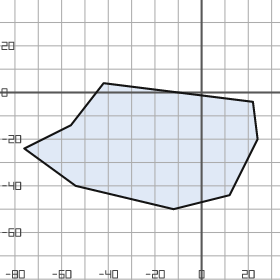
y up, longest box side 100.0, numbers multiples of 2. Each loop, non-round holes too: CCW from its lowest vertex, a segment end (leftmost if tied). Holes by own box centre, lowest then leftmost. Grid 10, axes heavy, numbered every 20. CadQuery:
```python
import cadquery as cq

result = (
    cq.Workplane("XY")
    .moveTo(-12.0, -50.0)
    .lineTo(12.0, -44.0)
    .lineTo(24.0, -20.0)
    .lineTo(22.0, -4.0)
    .lineTo(-42.0, 4.0)
    .lineTo(-56.0, -14.0)
    .lineTo(-76.0, -24.0)
    .lineTo(-54.0, -40.0)
    .close()
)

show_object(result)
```